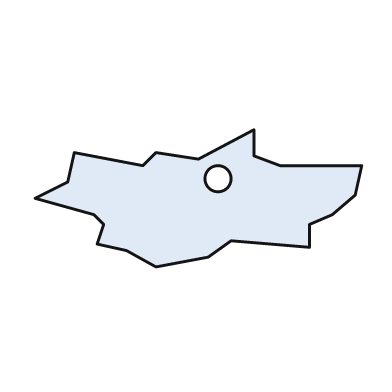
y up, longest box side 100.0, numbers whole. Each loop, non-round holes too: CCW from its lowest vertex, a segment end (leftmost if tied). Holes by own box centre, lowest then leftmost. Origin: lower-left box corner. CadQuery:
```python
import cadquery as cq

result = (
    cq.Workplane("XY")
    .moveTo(37.0, 0.0)
    .lineTo(53.0, 3.0)
    .lineTo(60.0, 8.0)
    .lineTo(84.0, 6.0)
    .lineTo(84.0, 13.0)
    .lineTo(91.0, 16.0)
    .lineTo(98.0, 22.0)
    .lineTo(100.0, 31.0)
    .lineTo(75.0, 31.0)
    .lineTo(67.0, 34.0)
    .lineTo(67.0, 42.0)
    .lineTo(50.0, 33.0)
    .lineTo(37.0, 35.0)
    .lineTo(33.0, 31.0)
    .lineTo(12.0, 35.0)
    .lineTo(10.0, 26.0)
    .lineTo(0.0, 21.0)
    .lineTo(18.0, 16.0)
    .lineTo(21.0, 13.0)
    .lineTo(19.0, 7.0)
    .lineTo(28.0, 5.0)
    .close()
    .moveTo(56.0, 27.0)
    .circle(4.0)
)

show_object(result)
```